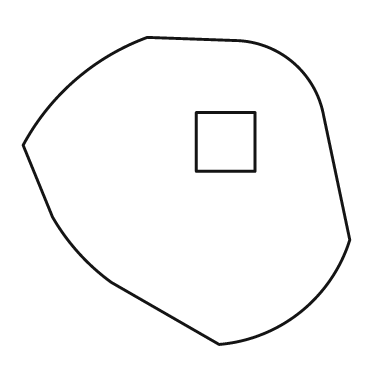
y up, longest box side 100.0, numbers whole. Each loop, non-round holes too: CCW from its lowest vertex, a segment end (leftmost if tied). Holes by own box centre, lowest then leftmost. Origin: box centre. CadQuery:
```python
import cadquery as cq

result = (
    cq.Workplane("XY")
    .moveTo(10.0, -47.0)
    .threePointArc((35.0, -37.0), (50.0, -15.0))
    .lineTo(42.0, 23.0)
    .threePointArc((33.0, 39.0), (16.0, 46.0))
    .lineTo(-12.0, 47.0)
    .threePointArc((-34.0, 34.0), (-50.0, 14.0))
    .lineTo(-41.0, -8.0)
    .threePointArc((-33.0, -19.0), (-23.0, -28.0))
    .close()
    .moveTo(3.0, 6.0)
    .lineTo(21.0, 6.0)
    .lineTo(21.0, 24.0)
    .lineTo(3.0, 24.0)
    .close()
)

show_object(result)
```